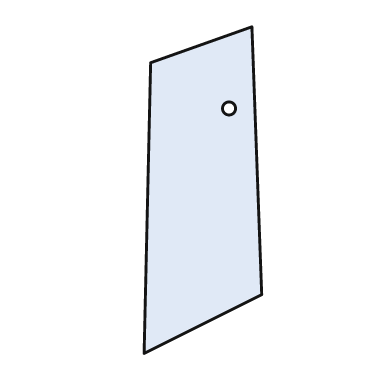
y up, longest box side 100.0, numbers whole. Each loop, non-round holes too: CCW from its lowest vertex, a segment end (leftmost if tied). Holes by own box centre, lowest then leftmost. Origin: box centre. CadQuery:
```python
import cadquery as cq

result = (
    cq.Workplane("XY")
    .moveTo(-18.0, -50.0)
    .lineTo(18.0, -32.0)
    .lineTo(15.0, 50.0)
    .lineTo(-16.0, 39.0)
    .close()
    .moveTo(8.0, 25.0)
    .circle(2.0)
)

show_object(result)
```